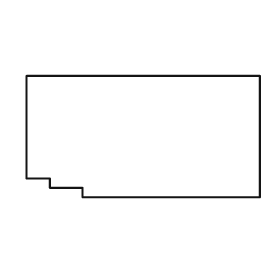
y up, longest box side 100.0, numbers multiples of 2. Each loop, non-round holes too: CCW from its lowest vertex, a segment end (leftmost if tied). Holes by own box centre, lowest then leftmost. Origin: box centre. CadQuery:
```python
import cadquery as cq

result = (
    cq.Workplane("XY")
    .moveTo(-26.0, -26.0)
    .lineTo(50.0, -26.0)
    .lineTo(50.0, 26.0)
    .lineTo(-50.0, 26.0)
    .lineTo(-50.0, -18.0)
    .lineTo(-40.0, -18.0)
    .lineTo(-40.0, -22.0)
    .lineTo(-26.0, -22.0)
    .close()
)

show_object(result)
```